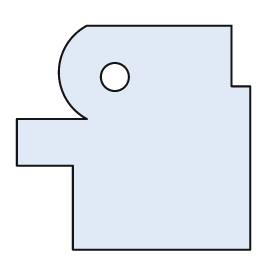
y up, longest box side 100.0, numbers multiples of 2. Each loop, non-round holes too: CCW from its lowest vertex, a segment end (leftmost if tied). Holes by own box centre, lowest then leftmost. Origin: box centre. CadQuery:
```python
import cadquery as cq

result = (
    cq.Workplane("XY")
    .moveTo(-26.0, -48.0)
    .lineTo(50.0, -48.0)
    .lineTo(50.0, 22.0)
    .lineTo(42.0, 22.0)
    .lineTo(42.0, 48.0)
    .lineTo(-20.0, 48.0)
    .threePointArc((-32.0, 28.0), (-20.0, 8.0))
    .lineTo(-50.0, 8.0)
    .lineTo(-50.0, -12.0)
    .lineTo(-26.0, -12.0)
    .close()
    .moveTo(-8.0, 26.0)
    .circle(6.0)
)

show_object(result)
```